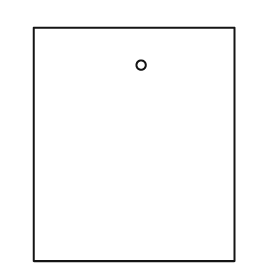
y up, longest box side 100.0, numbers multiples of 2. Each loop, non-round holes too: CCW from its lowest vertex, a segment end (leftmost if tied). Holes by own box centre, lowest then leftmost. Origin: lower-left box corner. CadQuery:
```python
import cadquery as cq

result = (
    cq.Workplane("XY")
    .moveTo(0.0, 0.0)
    .lineTo(86.0, 0.0)
    .lineTo(86.0, 100.0)
    .lineTo(0.0, 100.0)
    .close()
    .moveTo(46.0, 84.0)
    .circle(2.0)
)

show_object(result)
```